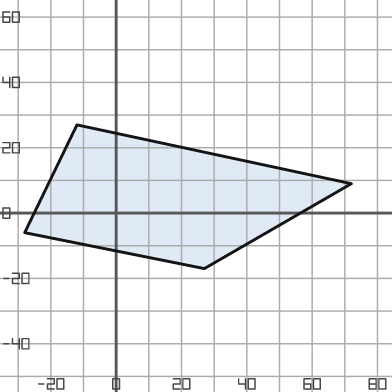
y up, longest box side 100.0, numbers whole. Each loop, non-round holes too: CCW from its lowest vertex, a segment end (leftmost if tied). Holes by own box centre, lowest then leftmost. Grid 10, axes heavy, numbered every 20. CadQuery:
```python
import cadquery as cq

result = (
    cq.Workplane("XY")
    .moveTo(27.0, -17.0)
    .lineTo(72.0, 9.0)
    .lineTo(-12.0, 27.0)
    .lineTo(-28.0, -6.0)
    .close()
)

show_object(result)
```